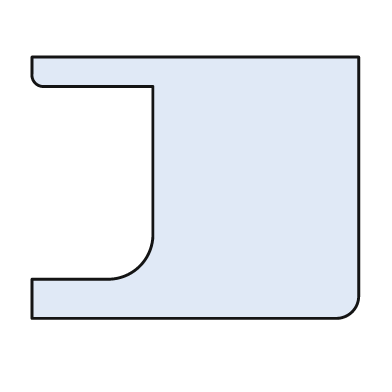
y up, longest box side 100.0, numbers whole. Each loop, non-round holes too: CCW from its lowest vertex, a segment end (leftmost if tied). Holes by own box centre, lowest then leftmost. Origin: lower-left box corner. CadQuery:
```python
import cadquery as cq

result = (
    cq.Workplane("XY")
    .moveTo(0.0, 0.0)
    .lineTo(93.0, 0.0)
    .threePointArc((98.0, 2.0), (100.0, 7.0))
    .lineTo(100.0, 80.0)
    .lineTo(0.0, 80.0)
    .lineTo(0.0, 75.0)
    .threePointArc((1.0, 72.0), (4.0, 71.0))
    .lineTo(37.0, 71.0)
    .lineTo(37.0, 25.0)
    .threePointArc((33.0, 16.0), (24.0, 12.0))
    .lineTo(0.0, 12.0)
    .close()
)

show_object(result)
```